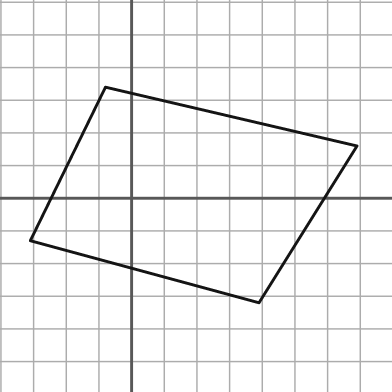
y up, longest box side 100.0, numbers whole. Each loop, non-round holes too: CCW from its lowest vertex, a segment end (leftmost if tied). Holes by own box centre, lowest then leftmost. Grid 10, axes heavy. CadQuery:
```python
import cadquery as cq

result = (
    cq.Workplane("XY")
    .moveTo(39.0, -32.0)
    .lineTo(69.0, 16.0)
    .lineTo(-8.0, 34.0)
    .lineTo(-31.0, -13.0)
    .close()
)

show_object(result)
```